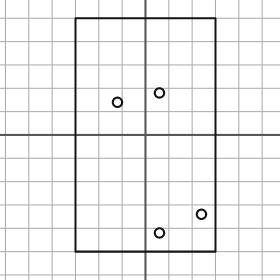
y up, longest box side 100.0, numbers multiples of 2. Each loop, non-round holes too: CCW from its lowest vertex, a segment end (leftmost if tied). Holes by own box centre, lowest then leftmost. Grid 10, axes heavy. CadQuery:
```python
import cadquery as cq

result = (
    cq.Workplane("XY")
    .moveTo(-30.0, -50.0)
    .lineTo(30.0, -50.0)
    .lineTo(30.0, 50.0)
    .lineTo(-30.0, 50.0)
    .close()
    .moveTo(6.0, -42.0)
    .circle(2.0)
    .moveTo(24.0, -34.0)
    .circle(2.0)
    .moveTo(-12.0, 14.0)
    .circle(2.0)
    .moveTo(6.0, 18.0)
    .circle(2.0)
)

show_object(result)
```